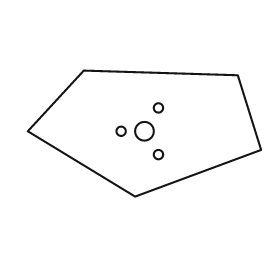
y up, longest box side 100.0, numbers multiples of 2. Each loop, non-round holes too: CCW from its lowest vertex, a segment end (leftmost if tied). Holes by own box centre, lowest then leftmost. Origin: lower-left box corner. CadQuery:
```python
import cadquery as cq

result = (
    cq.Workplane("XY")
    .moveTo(46.0, 0.0)
    .lineTo(100.0, 20.0)
    .lineTo(90.0, 52.0)
    .lineTo(24.0, 54.0)
    .lineTo(0.0, 28.0)
    .close()
    .moveTo(56.0, 18.0)
    .circle(2.0)
    .moveTo(40.0, 28.0)
    .circle(2.0)
    .moveTo(50.0, 28.0)
    .circle(4.0)
    .moveTo(56.0, 38.0)
    .circle(2.0)
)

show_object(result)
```